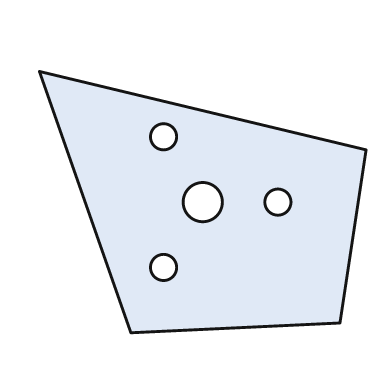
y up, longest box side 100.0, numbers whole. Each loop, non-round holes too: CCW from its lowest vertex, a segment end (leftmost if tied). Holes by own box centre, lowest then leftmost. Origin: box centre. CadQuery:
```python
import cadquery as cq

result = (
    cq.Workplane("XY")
    .moveTo(-22.0, -40.0)
    .lineTo(42.0, -37.0)
    .lineTo(50.0, 16.0)
    .lineTo(-50.0, 40.0)
    .close()
    .moveTo(-12.0, -20.0)
    .circle(4.0)
    .moveTo(0.0, 0.0)
    .circle(6.0)
    .moveTo(23.0, 0.0)
    .circle(4.0)
    .moveTo(-12.0, 20.0)
    .circle(4.0)
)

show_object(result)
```